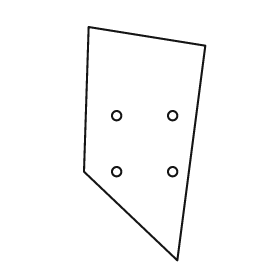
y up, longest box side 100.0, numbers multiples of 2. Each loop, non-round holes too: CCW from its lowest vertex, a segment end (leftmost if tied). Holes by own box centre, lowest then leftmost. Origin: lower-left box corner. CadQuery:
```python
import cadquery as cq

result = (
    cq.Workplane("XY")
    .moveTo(40.0, 0.0)
    .lineTo(52.0, 92.0)
    .lineTo(2.0, 100.0)
    .lineTo(0.0, 38.0)
    .close()
    .moveTo(14.0, 38.0)
    .circle(2.0)
    .moveTo(38.0, 38.0)
    .circle(2.0)
    .moveTo(14.0, 62.0)
    .circle(2.0)
    .moveTo(38.0, 62.0)
    .circle(2.0)
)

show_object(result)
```